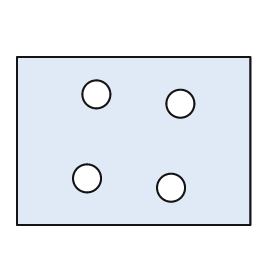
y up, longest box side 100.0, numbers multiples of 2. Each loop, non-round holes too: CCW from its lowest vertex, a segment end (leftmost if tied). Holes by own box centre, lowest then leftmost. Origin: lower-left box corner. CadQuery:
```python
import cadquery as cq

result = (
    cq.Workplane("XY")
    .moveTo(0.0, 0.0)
    .lineTo(100.0, 0.0)
    .lineTo(100.0, 72.0)
    .lineTo(0.0, 72.0)
    .close()
    .moveTo(66.0, 16.0)
    .circle(6.0)
    .moveTo(30.0, 20.0)
    .circle(6.0)
    .moveTo(70.0, 52.0)
    .circle(6.0)
    .moveTo(34.0, 56.0)
    .circle(6.0)
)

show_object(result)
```